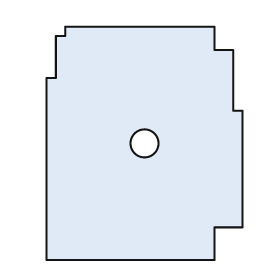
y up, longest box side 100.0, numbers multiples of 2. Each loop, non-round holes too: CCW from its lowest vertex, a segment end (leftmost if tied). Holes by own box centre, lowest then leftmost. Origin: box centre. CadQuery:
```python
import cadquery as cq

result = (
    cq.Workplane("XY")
    .moveTo(-42.0, -50.0)
    .lineTo(30.0, -50.0)
    .lineTo(30.0, -36.0)
    .lineTo(42.0, -36.0)
    .lineTo(42.0, 14.0)
    .lineTo(38.0, 14.0)
    .lineTo(38.0, 40.0)
    .lineTo(30.0, 40.0)
    .lineTo(30.0, 50.0)
    .lineTo(-34.0, 50.0)
    .lineTo(-34.0, 46.0)
    .lineTo(-38.0, 46.0)
    .lineTo(-38.0, 28.0)
    .lineTo(-42.0, 28.0)
    .close()
    .moveTo(0.0, 0.0)
    .circle(6.0)
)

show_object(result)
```